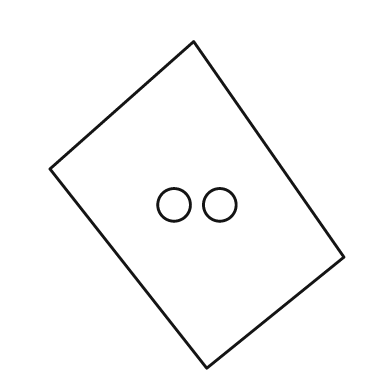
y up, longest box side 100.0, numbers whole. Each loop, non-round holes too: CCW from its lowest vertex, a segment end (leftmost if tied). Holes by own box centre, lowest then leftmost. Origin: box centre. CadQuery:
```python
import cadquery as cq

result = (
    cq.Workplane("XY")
    .moveTo(3.0, -50.0)
    .lineTo(45.0, -16.0)
    .lineTo(-1.0, 50.0)
    .lineTo(-45.0, 11.0)
    .close()
    .moveTo(-7.0, 0.0)
    .circle(5.0)
    .moveTo(7.0, 0.0)
    .circle(5.0)
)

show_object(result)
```